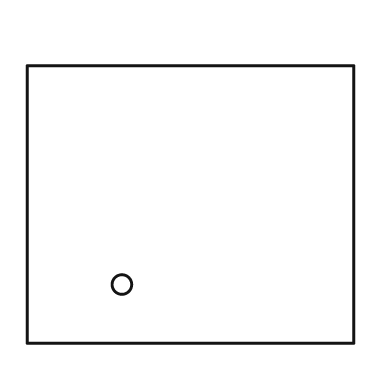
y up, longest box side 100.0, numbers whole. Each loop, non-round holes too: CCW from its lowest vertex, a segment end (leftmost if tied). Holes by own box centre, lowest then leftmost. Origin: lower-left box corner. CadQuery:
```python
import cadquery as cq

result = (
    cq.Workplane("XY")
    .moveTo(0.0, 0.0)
    .lineTo(100.0, 0.0)
    .lineTo(100.0, 85.0)
    .lineTo(0.0, 85.0)
    .close()
    .moveTo(29.0, 18.0)
    .circle(3.0)
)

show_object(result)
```